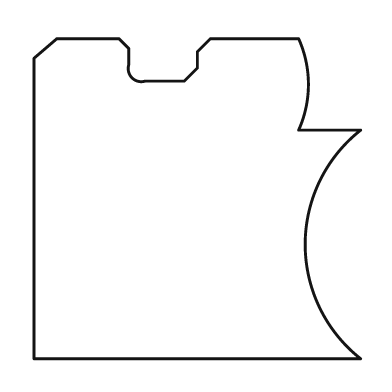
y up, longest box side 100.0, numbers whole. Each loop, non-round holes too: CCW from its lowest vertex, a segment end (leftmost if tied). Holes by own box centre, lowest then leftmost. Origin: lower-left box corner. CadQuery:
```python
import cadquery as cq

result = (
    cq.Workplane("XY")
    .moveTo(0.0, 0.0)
    .lineTo(100.0, 0.0)
    .threePointArc((83.0, 35.0), (100.0, 70.0))
    .lineTo(81.0, 70.0)
    .threePointArc((84.0, 84.0), (81.0, 98.0))
    .lineTo(54.0, 98.0)
    .lineTo(50.0, 94.0)
    .lineTo(50.0, 89.0)
    .lineTo(46.0, 85.0)
    .lineTo(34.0, 85.0)
    .threePointArc((30.0, 86.0), (29.0, 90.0))
    .lineTo(29.0, 95.0)
    .lineTo(26.0, 98.0)
    .lineTo(7.0, 98.0)
    .lineTo(0.0, 92.0)
    .close()
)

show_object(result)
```